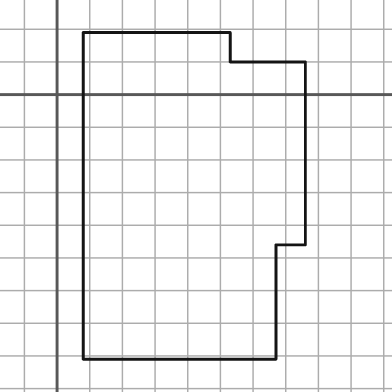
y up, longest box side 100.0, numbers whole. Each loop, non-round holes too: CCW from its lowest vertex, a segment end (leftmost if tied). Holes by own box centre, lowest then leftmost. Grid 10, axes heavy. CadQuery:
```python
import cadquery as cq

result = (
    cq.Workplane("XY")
    .moveTo(8.0, -81.0)
    .lineTo(67.0, -81.0)
    .lineTo(67.0, -46.0)
    .lineTo(76.0, -46.0)
    .lineTo(76.0, 10.0)
    .lineTo(53.0, 10.0)
    .lineTo(53.0, 19.0)
    .lineTo(8.0, 19.0)
    .close()
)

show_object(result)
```